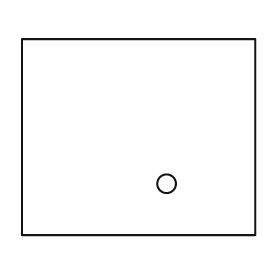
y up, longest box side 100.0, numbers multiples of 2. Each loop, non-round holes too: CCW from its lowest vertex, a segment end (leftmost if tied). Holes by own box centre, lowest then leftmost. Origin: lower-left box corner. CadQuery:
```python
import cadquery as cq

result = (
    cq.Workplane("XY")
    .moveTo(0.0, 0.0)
    .lineTo(100.0, 0.0)
    .lineTo(100.0, 84.0)
    .lineTo(0.0, 84.0)
    .close()
    .moveTo(62.0, 22.0)
    .circle(4.0)
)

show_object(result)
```